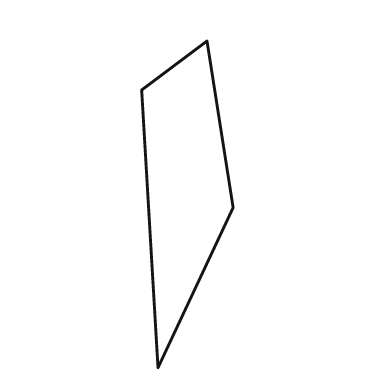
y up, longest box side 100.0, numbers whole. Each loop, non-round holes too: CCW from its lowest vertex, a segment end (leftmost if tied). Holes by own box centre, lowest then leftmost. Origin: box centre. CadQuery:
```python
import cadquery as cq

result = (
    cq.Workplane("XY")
    .moveTo(-9.0, -50.0)
    .lineTo(14.0, -1.0)
    .lineTo(6.0, 50.0)
    .lineTo(-14.0, 35.0)
    .close()
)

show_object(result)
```